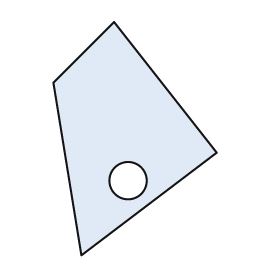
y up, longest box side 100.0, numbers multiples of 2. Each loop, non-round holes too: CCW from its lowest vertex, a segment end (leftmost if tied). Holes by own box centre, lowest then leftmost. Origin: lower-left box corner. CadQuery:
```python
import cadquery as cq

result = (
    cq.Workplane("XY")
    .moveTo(12.0, 0.0)
    .lineTo(70.0, 44.0)
    .lineTo(26.0, 100.0)
    .lineTo(0.0, 74.0)
    .close()
    .moveTo(32.0, 32.0)
    .circle(8.0)
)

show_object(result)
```